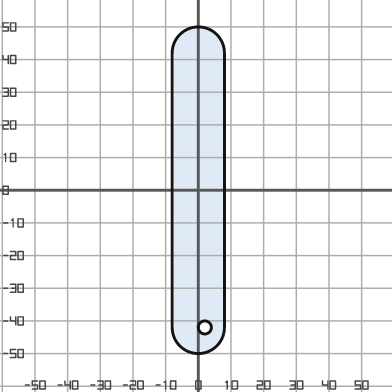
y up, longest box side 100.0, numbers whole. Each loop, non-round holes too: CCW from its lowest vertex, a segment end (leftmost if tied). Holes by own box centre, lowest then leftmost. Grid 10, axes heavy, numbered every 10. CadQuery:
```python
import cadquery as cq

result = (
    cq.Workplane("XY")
    .moveTo(-8.0, -42.0)
    .threePointArc((0.0, -50.0), (8.0, -42.0))
    .lineTo(8.0, 42.0)
    .threePointArc((0.0, 50.0), (-8.0, 42.0))
    .close()
    .moveTo(2.0, -42.0)
    .circle(2.0)
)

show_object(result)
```